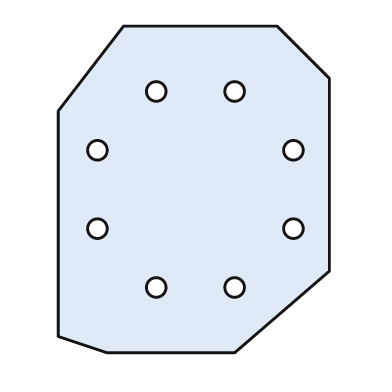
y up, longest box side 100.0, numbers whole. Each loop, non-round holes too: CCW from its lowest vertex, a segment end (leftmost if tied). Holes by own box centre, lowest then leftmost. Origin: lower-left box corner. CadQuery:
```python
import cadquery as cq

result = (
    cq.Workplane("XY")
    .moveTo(15.0, 0.0)
    .lineTo(54.0, 0.0)
    .lineTo(83.0, 25.0)
    .lineTo(83.0, 84.0)
    .lineTo(67.0, 100.0)
    .lineTo(20.0, 100.0)
    .lineTo(0.0, 74.0)
    .lineTo(0.0, 5.0)
    .close()
    .moveTo(30.0, 20.0)
    .circle(3.0)
    .moveTo(54.0, 20.0)
    .circle(3.0)
    .moveTo(12.0, 38.0)
    .circle(3.0)
    .moveTo(72.0, 38.0)
    .circle(3.0)
    .moveTo(12.0, 62.0)
    .circle(3.0)
    .moveTo(72.0, 62.0)
    .circle(3.0)
    .moveTo(30.0, 80.0)
    .circle(3.0)
    .moveTo(54.0, 80.0)
    .circle(3.0)
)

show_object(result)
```